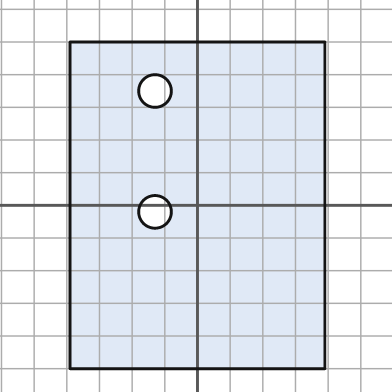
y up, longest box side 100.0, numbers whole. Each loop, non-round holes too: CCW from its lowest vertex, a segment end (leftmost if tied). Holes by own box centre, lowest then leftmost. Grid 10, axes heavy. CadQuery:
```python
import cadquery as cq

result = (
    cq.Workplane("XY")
    .moveTo(-39.0, -50.0)
    .lineTo(39.0, -50.0)
    .lineTo(39.0, 50.0)
    .lineTo(-39.0, 50.0)
    .close()
    .moveTo(-13.0, -2.0)
    .circle(5.0)
    .moveTo(-13.0, 35.0)
    .circle(5.0)
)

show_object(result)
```